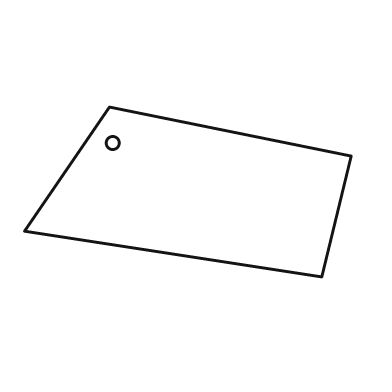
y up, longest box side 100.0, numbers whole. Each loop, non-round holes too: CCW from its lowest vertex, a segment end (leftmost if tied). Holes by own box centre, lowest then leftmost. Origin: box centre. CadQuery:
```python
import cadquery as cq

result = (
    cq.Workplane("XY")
    .moveTo(41.0, -26.0)
    .lineTo(50.0, 11.0)
    .lineTo(-24.0, 26.0)
    .lineTo(-50.0, -12.0)
    .close()
    .moveTo(-23.0, 15.0)
    .circle(2.0)
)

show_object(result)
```